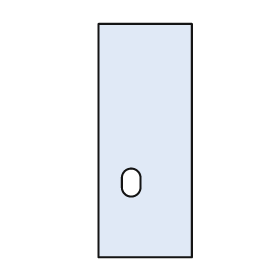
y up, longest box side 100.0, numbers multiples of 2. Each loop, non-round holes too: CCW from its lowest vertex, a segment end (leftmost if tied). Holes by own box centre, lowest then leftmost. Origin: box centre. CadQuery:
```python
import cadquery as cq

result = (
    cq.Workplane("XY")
    .moveTo(-20.0, -50.0)
    .lineTo(20.0, -50.0)
    .lineTo(20.0, 50.0)
    .lineTo(-20.0, 50.0)
    .close()
    .moveTo(-10.0, -20.0)
    .threePointArc((-6.0, -24.0), (-2.0, -20.0))
    .lineTo(-2.0, -16.0)
    .threePointArc((-6.0, -12.0), (-10.0, -16.0))
    .close()
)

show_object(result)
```